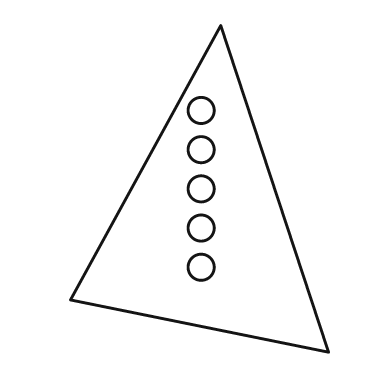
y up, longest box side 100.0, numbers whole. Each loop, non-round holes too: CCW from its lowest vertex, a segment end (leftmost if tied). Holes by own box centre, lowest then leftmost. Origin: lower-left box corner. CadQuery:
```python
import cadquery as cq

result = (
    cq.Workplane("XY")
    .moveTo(79.0, 0.0)
    .lineTo(46.0, 100.0)
    .lineTo(0.0, 16.0)
    .close()
    .moveTo(40.0, 26.0)
    .circle(4.0)
    .moveTo(40.0, 38.0)
    .circle(4.0)
    .moveTo(40.0, 50.0)
    .circle(4.0)
    .moveTo(40.0, 62.0)
    .circle(4.0)
    .moveTo(40.0, 74.0)
    .circle(4.0)
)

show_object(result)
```